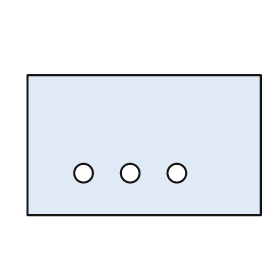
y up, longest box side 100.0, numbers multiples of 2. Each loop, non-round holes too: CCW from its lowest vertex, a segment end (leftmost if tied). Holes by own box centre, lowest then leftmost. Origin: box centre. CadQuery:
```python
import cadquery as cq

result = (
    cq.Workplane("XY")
    .moveTo(-50.0, -30.0)
    .lineTo(50.0, -30.0)
    .lineTo(50.0, 30.0)
    .lineTo(-50.0, 30.0)
    .close()
    .moveTo(-26.0, -12.0)
    .circle(4.0)
    .moveTo(-6.0, -12.0)
    .circle(4.0)
    .moveTo(14.0, -12.0)
    .circle(4.0)
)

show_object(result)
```